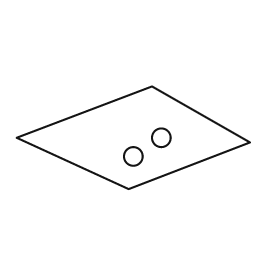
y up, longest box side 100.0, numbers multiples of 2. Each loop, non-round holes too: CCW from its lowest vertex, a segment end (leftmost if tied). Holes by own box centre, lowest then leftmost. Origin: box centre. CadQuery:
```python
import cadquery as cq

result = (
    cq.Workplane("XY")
    .moveTo(-2.0, -22.0)
    .lineTo(50.0, -2.0)
    .lineTo(8.0, 22.0)
    .lineTo(-50.0, 0.0)
    .close()
    .moveTo(0.0, -8.0)
    .circle(4.0)
    .moveTo(12.0, 0.0)
    .circle(4.0)
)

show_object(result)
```